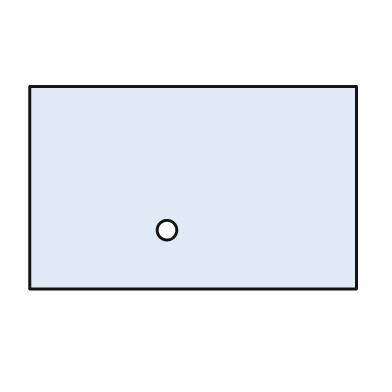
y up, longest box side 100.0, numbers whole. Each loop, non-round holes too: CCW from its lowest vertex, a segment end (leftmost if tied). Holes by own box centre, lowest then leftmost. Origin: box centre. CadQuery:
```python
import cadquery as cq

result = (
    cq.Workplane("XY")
    .moveTo(-50.0, -31.0)
    .lineTo(50.0, -31.0)
    .lineTo(50.0, 31.0)
    .lineTo(-50.0, 31.0)
    .close()
    .moveTo(-8.0, -13.0)
    .circle(3.0)
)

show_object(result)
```